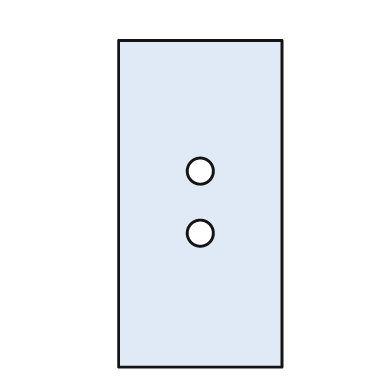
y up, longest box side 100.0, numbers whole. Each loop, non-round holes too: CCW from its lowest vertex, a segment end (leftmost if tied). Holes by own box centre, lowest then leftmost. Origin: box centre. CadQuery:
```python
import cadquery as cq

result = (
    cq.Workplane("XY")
    .moveTo(-25.0, -50.0)
    .lineTo(25.0, -50.0)
    .lineTo(25.0, 50.0)
    .lineTo(-25.0, 50.0)
    .close()
    .moveTo(0.0, -9.0)
    .circle(4.0)
    .moveTo(0.0, 10.0)
    .circle(4.0)
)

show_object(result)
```